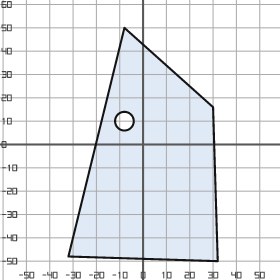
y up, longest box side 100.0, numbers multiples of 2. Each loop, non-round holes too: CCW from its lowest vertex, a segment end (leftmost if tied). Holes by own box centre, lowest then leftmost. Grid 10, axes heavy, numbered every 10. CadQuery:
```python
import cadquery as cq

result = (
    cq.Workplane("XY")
    .moveTo(32.0, -50.0)
    .lineTo(30.0, 16.0)
    .lineTo(-8.0, 50.0)
    .lineTo(-32.0, -48.0)
    .close()
    .moveTo(-8.0, 10.0)
    .circle(4.0)
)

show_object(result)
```